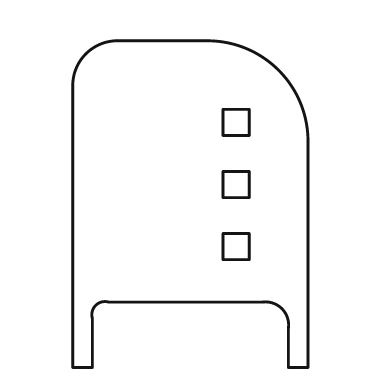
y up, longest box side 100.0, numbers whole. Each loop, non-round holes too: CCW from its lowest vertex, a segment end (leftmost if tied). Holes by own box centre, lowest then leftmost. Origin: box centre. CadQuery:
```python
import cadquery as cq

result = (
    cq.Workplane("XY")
    .moveTo(-36.0, -50.0)
    .lineTo(-30.0, -50.0)
    .lineTo(-30.0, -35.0)
    .threePointArc((-29.0, -31.0), (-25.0, -30.0))
    .lineTo(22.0, -30.0)
    .threePointArc((28.0, -32.0), (30.0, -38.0))
    .lineTo(30.0, -50.0)
    .lineTo(36.0, -50.0)
    .lineTo(36.0, 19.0)
    .threePointArc((27.0, 41.0), (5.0, 50.0))
    .lineTo(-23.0, 50.0)
    .threePointArc((-32.0, 46.0), (-36.0, 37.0))
    .close()
    .moveTo(10.0, -17.0)
    .lineTo(18.0, -17.0)
    .lineTo(18.0, -9.0)
    .lineTo(10.0, -9.0)
    .close()
    .moveTo(10.0, 2.0)
    .lineTo(18.0, 2.0)
    .lineTo(18.0, 10.0)
    .lineTo(10.0, 10.0)
    .close()
    .moveTo(10.0, 21.0)
    .lineTo(18.0, 21.0)
    .lineTo(18.0, 29.0)
    .lineTo(10.0, 29.0)
    .close()
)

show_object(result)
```